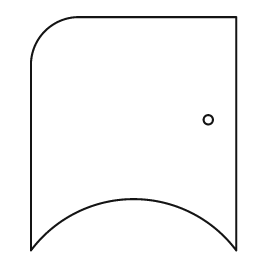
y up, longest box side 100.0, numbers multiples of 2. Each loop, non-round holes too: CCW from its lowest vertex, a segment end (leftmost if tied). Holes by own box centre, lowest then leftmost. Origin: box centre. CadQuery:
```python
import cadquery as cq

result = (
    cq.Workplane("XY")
    .moveTo(-44.0, -50.0)
    .threePointArc((0.0, -28.0), (44.0, -50.0))
    .lineTo(44.0, 50.0)
    .lineTo(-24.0, 50.0)
    .threePointArc((-38.0, 44.0), (-44.0, 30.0))
    .close()
    .moveTo(32.0, 6.0)
    .circle(2.0)
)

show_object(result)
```